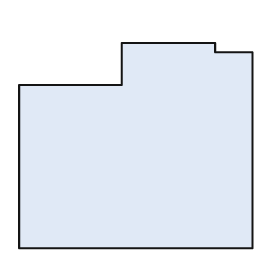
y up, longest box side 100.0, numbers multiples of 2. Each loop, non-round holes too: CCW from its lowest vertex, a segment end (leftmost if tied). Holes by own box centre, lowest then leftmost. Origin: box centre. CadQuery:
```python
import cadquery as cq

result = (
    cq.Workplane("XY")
    .moveTo(-50.0, -44.0)
    .lineTo(50.0, -44.0)
    .lineTo(50.0, 40.0)
    .lineTo(34.0, 40.0)
    .lineTo(34.0, 44.0)
    .lineTo(-6.0, 44.0)
    .lineTo(-6.0, 26.0)
    .lineTo(-50.0, 26.0)
    .close()
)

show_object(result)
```